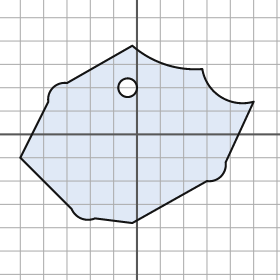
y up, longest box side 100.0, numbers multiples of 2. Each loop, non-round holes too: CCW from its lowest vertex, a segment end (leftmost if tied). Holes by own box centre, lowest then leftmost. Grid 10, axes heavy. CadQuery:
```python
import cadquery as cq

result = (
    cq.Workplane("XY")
    .moveTo(-2.0, -38.0)
    .lineTo(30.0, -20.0)
    .threePointArc((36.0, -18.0), (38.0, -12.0))
    .lineTo(50.0, 14.0)
    .threePointArc((36.0, 16.0), (28.0, 28.0))
    .threePointArc((12.0, 30.0), (-2.0, 38.0))
    .lineTo(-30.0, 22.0)
    .threePointArc((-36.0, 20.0), (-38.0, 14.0))
    .lineTo(-50.0, -10.0)
    .lineTo(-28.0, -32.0)
    .threePointArc((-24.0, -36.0), (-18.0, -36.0))
    .close()
    .moveTo(-4.0, 20.0)
    .circle(4.0)
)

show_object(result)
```